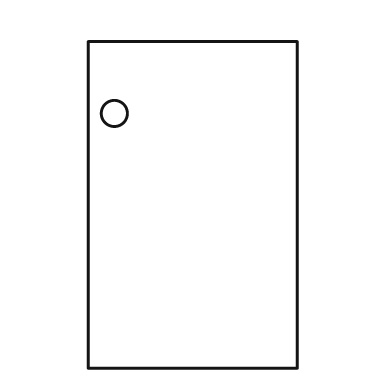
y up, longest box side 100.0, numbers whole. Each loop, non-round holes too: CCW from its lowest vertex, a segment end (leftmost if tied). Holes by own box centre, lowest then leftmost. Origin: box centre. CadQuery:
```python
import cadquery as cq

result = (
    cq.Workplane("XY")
    .moveTo(-32.0, -50.0)
    .lineTo(32.0, -50.0)
    .lineTo(32.0, 50.0)
    .lineTo(-32.0, 50.0)
    .close()
    .moveTo(-24.0, 28.0)
    .circle(4.0)
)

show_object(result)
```